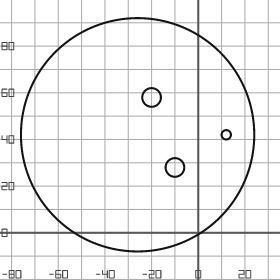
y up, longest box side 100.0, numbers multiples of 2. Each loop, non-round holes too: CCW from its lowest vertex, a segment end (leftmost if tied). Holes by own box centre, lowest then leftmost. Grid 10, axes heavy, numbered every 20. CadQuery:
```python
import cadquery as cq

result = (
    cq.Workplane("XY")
    .moveTo(-26.0, 42.0)
    .circle(50.0)
    .moveTo(-10.0, 28.0)
    .circle(4.0)
    .moveTo(12.0, 42.0)
    .circle(2.0)
    .moveTo(-20.0, 58.0)
    .circle(4.0)
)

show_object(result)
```